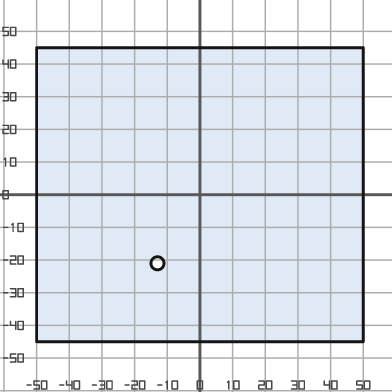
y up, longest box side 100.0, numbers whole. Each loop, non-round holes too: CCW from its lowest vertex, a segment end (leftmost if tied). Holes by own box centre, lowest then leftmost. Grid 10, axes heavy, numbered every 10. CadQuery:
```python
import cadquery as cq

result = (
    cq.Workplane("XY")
    .moveTo(-50.0, -45.0)
    .lineTo(50.0, -45.0)
    .lineTo(50.0, 45.0)
    .lineTo(-50.0, 45.0)
    .close()
    .moveTo(-13.0, -21.0)
    .circle(2.0)
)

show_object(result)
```